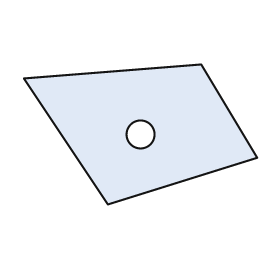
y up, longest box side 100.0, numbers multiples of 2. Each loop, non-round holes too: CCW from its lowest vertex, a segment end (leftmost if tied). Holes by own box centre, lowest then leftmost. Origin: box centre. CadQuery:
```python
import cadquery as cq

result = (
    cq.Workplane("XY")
    .moveTo(-14.0, -30.0)
    .lineTo(50.0, -10.0)
    .lineTo(26.0, 30.0)
    .lineTo(-50.0, 24.0)
    .close()
    .moveTo(0.0, 0.0)
    .circle(6.0)
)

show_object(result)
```